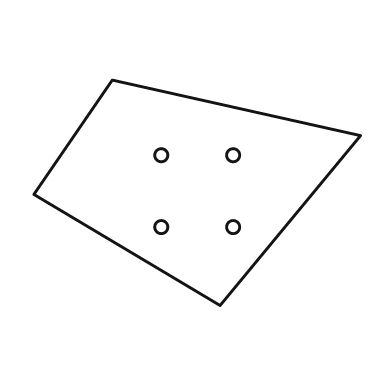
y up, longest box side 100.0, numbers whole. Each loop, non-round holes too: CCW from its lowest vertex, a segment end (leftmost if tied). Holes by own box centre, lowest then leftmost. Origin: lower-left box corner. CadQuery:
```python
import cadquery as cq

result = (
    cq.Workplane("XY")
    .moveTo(57.0, 0.0)
    .lineTo(100.0, 52.0)
    .lineTo(24.0, 69.0)
    .lineTo(0.0, 34.0)
    .close()
    .moveTo(39.0, 24.0)
    .circle(2.0)
    .moveTo(61.0, 24.0)
    .circle(2.0)
    .moveTo(39.0, 46.0)
    .circle(2.0)
    .moveTo(61.0, 46.0)
    .circle(2.0)
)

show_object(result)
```